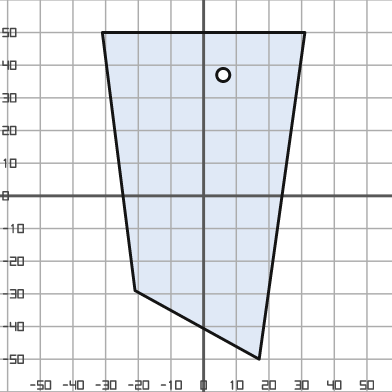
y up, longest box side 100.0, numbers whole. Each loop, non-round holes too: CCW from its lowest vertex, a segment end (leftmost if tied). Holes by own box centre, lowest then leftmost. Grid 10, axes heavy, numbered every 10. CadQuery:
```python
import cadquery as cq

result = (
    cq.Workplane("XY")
    .moveTo(17.0, -50.0)
    .lineTo(31.0, 50.0)
    .lineTo(-31.0, 50.0)
    .lineTo(-21.0, -29.0)
    .close()
    .moveTo(6.0, 37.0)
    .circle(2.0)
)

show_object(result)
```